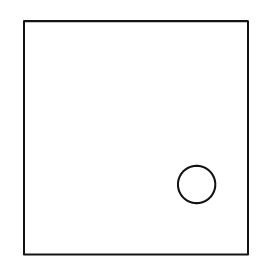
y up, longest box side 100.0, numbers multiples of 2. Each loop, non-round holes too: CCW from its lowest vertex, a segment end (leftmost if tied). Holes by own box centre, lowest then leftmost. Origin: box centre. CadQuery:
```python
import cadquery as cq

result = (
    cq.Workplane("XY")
    .moveTo(-48.0, -50.0)
    .lineTo(48.0, -50.0)
    .lineTo(48.0, 50.0)
    .lineTo(-48.0, 50.0)
    .close()
    .moveTo(26.0, -20.0)
    .circle(8.0)
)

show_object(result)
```